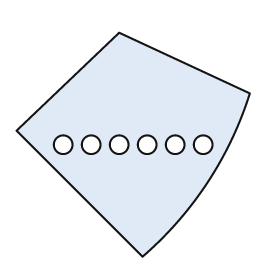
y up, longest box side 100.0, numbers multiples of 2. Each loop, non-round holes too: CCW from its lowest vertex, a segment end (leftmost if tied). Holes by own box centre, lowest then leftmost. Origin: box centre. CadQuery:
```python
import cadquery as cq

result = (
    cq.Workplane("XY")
    .moveTo(4.0, -48.0)
    .threePointArc((32.0, -16.0), (50.0, 22.0))
    .lineTo(-6.0, 48.0)
    .lineTo(-50.0, 6.0)
    .close()
    .moveTo(-30.0, 0.0)
    .circle(4.0)
    .moveTo(-18.0, 0.0)
    .circle(4.0)
    .moveTo(-6.0, 0.0)
    .circle(4.0)
    .moveTo(6.0, 0.0)
    .circle(4.0)
    .moveTo(18.0, 0.0)
    .circle(4.0)
    .moveTo(30.0, 0.0)
    .circle(4.0)
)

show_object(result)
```